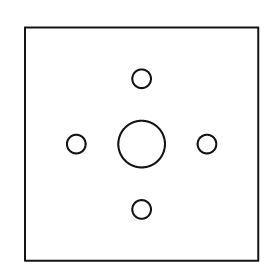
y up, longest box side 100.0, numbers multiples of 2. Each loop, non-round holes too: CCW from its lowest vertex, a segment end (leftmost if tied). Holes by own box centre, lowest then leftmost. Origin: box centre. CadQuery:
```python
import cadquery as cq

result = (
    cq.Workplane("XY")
    .moveTo(-50.0, -50.0)
    .lineTo(50.0, -50.0)
    .lineTo(50.0, 50.0)
    .lineTo(-50.0, 50.0)
    .close()
    .moveTo(0.0, -28.0)
    .circle(4.0)
    .moveTo(-28.0, 0.0)
    .circle(4.0)
    .moveTo(0.0, 0.0)
    .circle(10.0)
    .moveTo(28.0, 0.0)
    .circle(4.0)
    .moveTo(0.0, 28.0)
    .circle(4.0)
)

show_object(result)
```